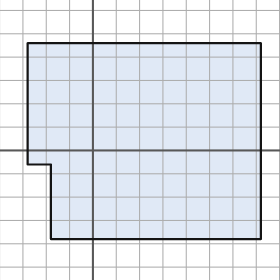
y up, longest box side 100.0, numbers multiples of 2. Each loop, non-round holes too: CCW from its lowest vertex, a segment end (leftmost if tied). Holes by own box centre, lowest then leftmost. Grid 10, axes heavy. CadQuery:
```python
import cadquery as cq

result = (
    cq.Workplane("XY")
    .moveTo(-18.0, -38.0)
    .lineTo(72.0, -38.0)
    .lineTo(72.0, 46.0)
    .lineTo(-28.0, 46.0)
    .lineTo(-28.0, -6.0)
    .lineTo(-18.0, -6.0)
    .close()
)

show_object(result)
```